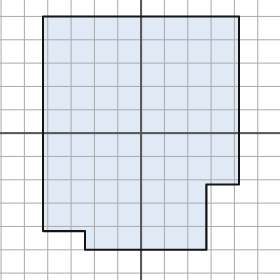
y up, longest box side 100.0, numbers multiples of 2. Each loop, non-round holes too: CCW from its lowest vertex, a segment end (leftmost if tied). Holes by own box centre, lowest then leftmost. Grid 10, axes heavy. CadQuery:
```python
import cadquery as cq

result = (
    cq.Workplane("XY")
    .moveTo(-24.0, -50.0)
    .lineTo(28.0, -50.0)
    .lineTo(28.0, -22.0)
    .lineTo(42.0, -22.0)
    .lineTo(42.0, 50.0)
    .lineTo(-42.0, 50.0)
    .lineTo(-42.0, -42.0)
    .lineTo(-24.0, -42.0)
    .close()
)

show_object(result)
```